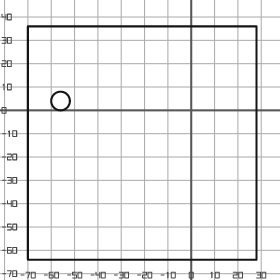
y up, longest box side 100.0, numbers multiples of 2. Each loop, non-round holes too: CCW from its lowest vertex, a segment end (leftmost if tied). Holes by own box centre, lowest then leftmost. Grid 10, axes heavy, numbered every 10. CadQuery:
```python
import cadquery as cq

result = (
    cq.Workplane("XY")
    .moveTo(-70.0, -64.0)
    .lineTo(28.0, -64.0)
    .lineTo(28.0, 36.0)
    .lineTo(-70.0, 36.0)
    .close()
    .moveTo(-56.0, 4.0)
    .circle(4.0)
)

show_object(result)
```